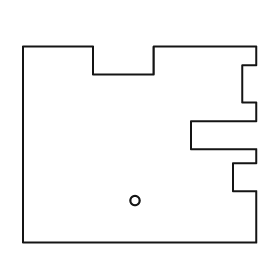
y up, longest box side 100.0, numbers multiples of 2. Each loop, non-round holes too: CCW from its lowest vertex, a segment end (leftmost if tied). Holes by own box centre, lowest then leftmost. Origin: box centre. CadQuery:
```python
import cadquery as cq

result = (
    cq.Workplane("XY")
    .moveTo(-50.0, -42.0)
    .lineTo(50.0, -42.0)
    .lineTo(50.0, -20.0)
    .lineTo(40.0, -20.0)
    .lineTo(40.0, -8.0)
    .lineTo(50.0, -8.0)
    .lineTo(50.0, -2.0)
    .lineTo(22.0, -2.0)
    .lineTo(22.0, 10.0)
    .lineTo(50.0, 10.0)
    .lineTo(50.0, 18.0)
    .lineTo(44.0, 18.0)
    .lineTo(44.0, 34.0)
    .lineTo(50.0, 34.0)
    .lineTo(50.0, 42.0)
    .lineTo(6.0, 42.0)
    .lineTo(6.0, 30.0)
    .lineTo(-20.0, 30.0)
    .lineTo(-20.0, 42.0)
    .lineTo(-50.0, 42.0)
    .close()
    .moveTo(-2.0, -24.0)
    .circle(2.0)
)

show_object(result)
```